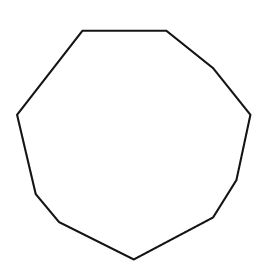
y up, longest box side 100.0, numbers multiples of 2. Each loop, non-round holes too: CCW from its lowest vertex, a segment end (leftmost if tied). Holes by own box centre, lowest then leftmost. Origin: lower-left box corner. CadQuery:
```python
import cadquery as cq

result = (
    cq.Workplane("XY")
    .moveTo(50.0, 0.0)
    .lineTo(84.0, 18.0)
    .lineTo(94.0, 34.0)
    .lineTo(100.0, 62.0)
    .lineTo(84.0, 82.0)
    .lineTo(64.0, 98.0)
    .lineTo(28.0, 98.0)
    .lineTo(0.0, 62.0)
    .lineTo(8.0, 28.0)
    .lineTo(18.0, 16.0)
    .close()
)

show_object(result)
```